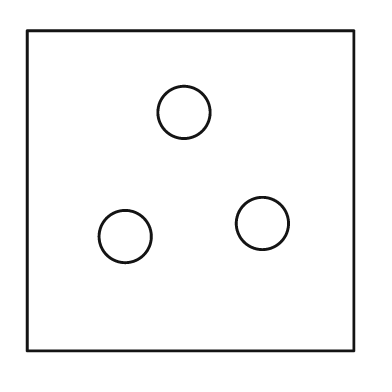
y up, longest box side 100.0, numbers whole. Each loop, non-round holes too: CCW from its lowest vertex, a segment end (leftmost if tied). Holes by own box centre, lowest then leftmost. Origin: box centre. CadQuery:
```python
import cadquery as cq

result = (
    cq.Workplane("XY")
    .moveTo(-50.0, -49.0)
    .lineTo(50.0, -49.0)
    .lineTo(50.0, 49.0)
    .lineTo(-50.0, 49.0)
    .close()
    .moveTo(-20.0, -14.0)
    .circle(8.0)
    .moveTo(22.0, -10.0)
    .circle(8.0)
    .moveTo(-2.0, 24.0)
    .circle(8.0)
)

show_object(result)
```